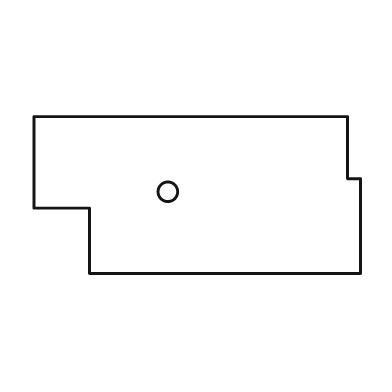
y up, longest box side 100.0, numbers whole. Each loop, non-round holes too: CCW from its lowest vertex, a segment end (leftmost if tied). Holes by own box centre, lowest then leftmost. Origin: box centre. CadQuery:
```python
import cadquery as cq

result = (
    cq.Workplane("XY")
    .moveTo(-33.0, -24.0)
    .lineTo(50.0, -24.0)
    .lineTo(50.0, 5.0)
    .lineTo(46.0, 5.0)
    .lineTo(46.0, 24.0)
    .lineTo(-50.0, 24.0)
    .lineTo(-50.0, -4.0)
    .lineTo(-33.0, -4.0)
    .close()
    .moveTo(-9.0, 1.0)
    .circle(3.0)
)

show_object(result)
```